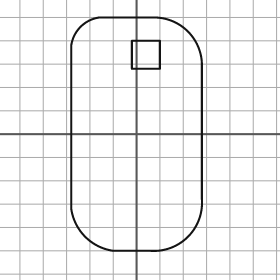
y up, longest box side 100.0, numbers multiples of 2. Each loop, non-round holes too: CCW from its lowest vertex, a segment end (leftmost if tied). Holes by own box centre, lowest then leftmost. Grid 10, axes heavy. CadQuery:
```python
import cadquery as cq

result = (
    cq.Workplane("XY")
    .moveTo(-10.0, -50.0)
    .lineTo(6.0, -50.0)
    .threePointArc((22.0, -44.0), (28.0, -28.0))
    .lineTo(28.0, 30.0)
    .threePointArc((22.0, 44.0), (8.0, 50.0))
    .lineTo(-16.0, 50.0)
    .threePointArc((-24.0, 46.0), (-28.0, 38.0))
    .lineTo(-28.0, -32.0)
    .threePointArc((-22.0, -44.0), (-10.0, -50.0))
    .close()
    .moveTo(-2.0, 28.0)
    .lineTo(10.0, 28.0)
    .lineTo(10.0, 40.0)
    .lineTo(-2.0, 40.0)
    .close()
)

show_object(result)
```